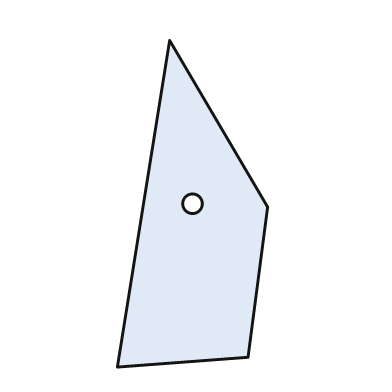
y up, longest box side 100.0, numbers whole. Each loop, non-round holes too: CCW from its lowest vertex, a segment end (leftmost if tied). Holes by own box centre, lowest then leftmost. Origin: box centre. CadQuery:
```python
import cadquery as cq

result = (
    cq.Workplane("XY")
    .moveTo(-23.0, -50.0)
    .lineTo(17.0, -47.0)
    .lineTo(23.0, -1.0)
    .lineTo(-7.0, 50.0)
    .close()
    .moveTo(0.0, 0.0)
    .circle(3.0)
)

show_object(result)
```